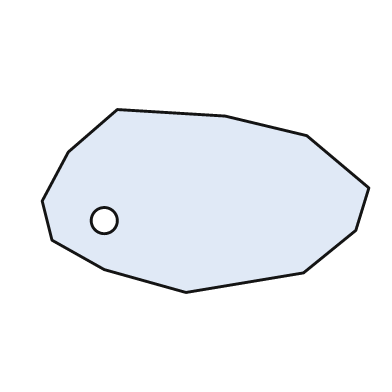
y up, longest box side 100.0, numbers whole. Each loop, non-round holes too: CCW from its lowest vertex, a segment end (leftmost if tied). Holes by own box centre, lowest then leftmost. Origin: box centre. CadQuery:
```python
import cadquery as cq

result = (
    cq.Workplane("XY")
    .moveTo(-6.0, -28.0)
    .lineTo(30.0, -22.0)
    .lineTo(46.0, -9.0)
    .lineTo(50.0, 4.0)
    .lineTo(31.0, 20.0)
    .lineTo(6.0, 26.0)
    .lineTo(-27.0, 28.0)
    .lineTo(-42.0, 15.0)
    .lineTo(-50.0, 0.0)
    .lineTo(-47.0, -12.0)
    .lineTo(-31.0, -21.0)
    .close()
    .moveTo(-31.0, -6.0)
    .circle(4.0)
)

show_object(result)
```